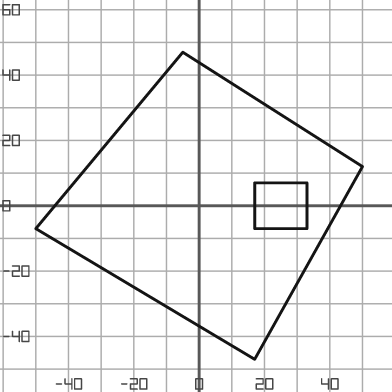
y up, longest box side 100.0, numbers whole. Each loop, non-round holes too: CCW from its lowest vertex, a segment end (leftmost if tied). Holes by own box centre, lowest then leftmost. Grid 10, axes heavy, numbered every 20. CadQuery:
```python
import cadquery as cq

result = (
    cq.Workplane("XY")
    .moveTo(17.0, -47.0)
    .lineTo(50.0, 12.0)
    .lineTo(-5.0, 47.0)
    .lineTo(-50.0, -7.0)
    .close()
    .moveTo(17.0, -7.0)
    .lineTo(33.0, -7.0)
    .lineTo(33.0, 7.0)
    .lineTo(17.0, 7.0)
    .close()
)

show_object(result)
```